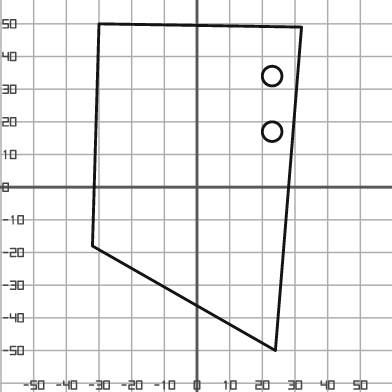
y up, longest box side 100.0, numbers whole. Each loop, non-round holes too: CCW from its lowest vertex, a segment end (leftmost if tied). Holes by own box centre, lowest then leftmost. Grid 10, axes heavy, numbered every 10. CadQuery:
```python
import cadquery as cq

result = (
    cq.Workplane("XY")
    .moveTo(24.0, -50.0)
    .lineTo(32.0, 49.0)
    .lineTo(-30.0, 50.0)
    .lineTo(-32.0, -18.0)
    .close()
    .moveTo(23.0, 17.0)
    .circle(3.0)
    .moveTo(23.0, 34.0)
    .circle(3.0)
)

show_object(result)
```